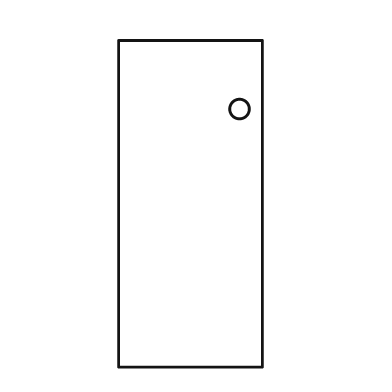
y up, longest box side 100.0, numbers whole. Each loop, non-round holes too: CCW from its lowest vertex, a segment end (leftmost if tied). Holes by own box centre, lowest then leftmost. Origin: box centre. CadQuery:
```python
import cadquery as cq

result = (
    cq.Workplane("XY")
    .moveTo(-22.0, -50.0)
    .lineTo(22.0, -50.0)
    .lineTo(22.0, 50.0)
    .lineTo(-22.0, 50.0)
    .close()
    .moveTo(15.0, 29.0)
    .circle(3.0)
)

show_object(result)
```